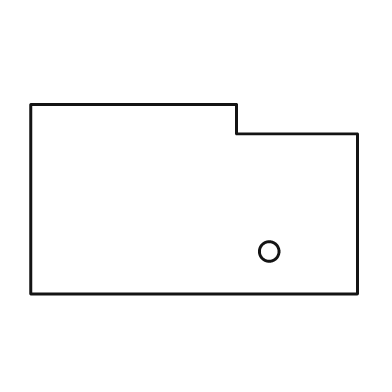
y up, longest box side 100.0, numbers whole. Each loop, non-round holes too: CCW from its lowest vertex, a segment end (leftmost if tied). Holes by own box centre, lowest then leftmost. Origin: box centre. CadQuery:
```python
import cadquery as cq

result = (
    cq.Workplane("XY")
    .moveTo(-50.0, -29.0)
    .lineTo(50.0, -29.0)
    .lineTo(50.0, 20.0)
    .lineTo(13.0, 20.0)
    .lineTo(13.0, 29.0)
    .lineTo(-50.0, 29.0)
    .close()
    .moveTo(23.0, -16.0)
    .circle(3.0)
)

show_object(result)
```